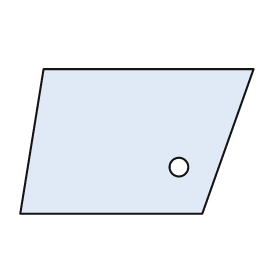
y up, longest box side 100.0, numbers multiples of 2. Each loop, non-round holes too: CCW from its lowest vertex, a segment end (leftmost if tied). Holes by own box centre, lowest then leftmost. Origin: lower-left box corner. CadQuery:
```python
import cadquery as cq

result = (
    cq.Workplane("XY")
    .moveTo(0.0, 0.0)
    .lineTo(78.0, 0.0)
    .lineTo(100.0, 62.0)
    .lineTo(10.0, 62.0)
    .close()
    .moveTo(68.0, 20.0)
    .circle(4.0)
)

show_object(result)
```